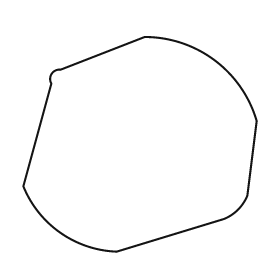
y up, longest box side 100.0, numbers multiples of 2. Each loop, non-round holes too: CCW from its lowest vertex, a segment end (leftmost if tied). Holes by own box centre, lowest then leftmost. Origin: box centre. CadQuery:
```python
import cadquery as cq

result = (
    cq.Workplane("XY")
    .moveTo(-10.0, -46.0)
    .lineTo(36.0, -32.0)
    .threePointArc((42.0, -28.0), (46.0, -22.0))
    .lineTo(50.0, 10.0)
    .threePointArc((32.0, 36.0), (2.0, 46.0))
    .lineTo(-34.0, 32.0)
    .threePointArc((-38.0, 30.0), (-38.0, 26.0))
    .lineTo(-50.0, -18.0)
    .threePointArc((-34.0, -38.0), (-10.0, -46.0))
    .close()
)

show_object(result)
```